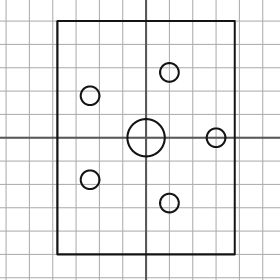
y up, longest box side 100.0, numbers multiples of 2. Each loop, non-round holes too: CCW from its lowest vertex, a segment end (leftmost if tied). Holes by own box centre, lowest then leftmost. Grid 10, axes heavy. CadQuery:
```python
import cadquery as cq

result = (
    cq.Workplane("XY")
    .moveTo(-38.0, -50.0)
    .lineTo(38.0, -50.0)
    .lineTo(38.0, 50.0)
    .lineTo(-38.0, 50.0)
    .close()
    .moveTo(10.0, -28.0)
    .circle(4.0)
    .moveTo(-24.0, -18.0)
    .circle(4.0)
    .moveTo(0.0, 0.0)
    .circle(8.0)
    .moveTo(30.0, 0.0)
    .circle(4.0)
    .moveTo(-24.0, 18.0)
    .circle(4.0)
    .moveTo(10.0, 28.0)
    .circle(4.0)
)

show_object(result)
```